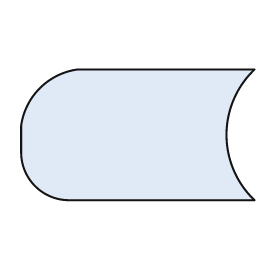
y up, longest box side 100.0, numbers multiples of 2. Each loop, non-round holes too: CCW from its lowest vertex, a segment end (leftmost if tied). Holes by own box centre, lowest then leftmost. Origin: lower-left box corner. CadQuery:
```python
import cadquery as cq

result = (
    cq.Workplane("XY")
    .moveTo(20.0, 0.0)
    .lineTo(100.0, 0.0)
    .threePointArc((88.0, 28.0), (100.0, 56.0))
    .lineTo(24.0, 56.0)
    .threePointArc((8.0, 48.0), (0.0, 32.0))
    .lineTo(0.0, 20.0)
    .threePointArc((6.0, 6.0), (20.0, 0.0))
    .close()
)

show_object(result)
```